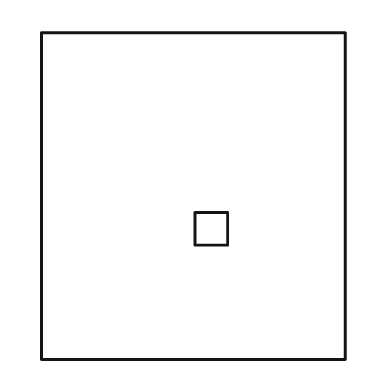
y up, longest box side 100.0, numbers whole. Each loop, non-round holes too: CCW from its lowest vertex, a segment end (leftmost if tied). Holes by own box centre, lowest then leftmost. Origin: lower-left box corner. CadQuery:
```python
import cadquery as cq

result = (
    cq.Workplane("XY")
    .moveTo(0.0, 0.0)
    .lineTo(93.0, 0.0)
    .lineTo(93.0, 100.0)
    .lineTo(0.0, 100.0)
    .close()
    .moveTo(47.0, 35.0)
    .lineTo(57.0, 35.0)
    .lineTo(57.0, 45.0)
    .lineTo(47.0, 45.0)
    .close()
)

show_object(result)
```